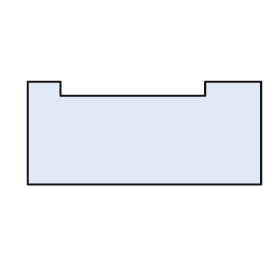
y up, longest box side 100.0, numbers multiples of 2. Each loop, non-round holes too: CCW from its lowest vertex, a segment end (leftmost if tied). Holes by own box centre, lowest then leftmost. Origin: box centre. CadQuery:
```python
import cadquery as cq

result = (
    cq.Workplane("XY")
    .moveTo(-50.0, -22.0)
    .lineTo(50.0, -22.0)
    .lineTo(50.0, 22.0)
    .lineTo(26.0, 22.0)
    .lineTo(26.0, 16.0)
    .lineTo(-36.0, 16.0)
    .lineTo(-36.0, 22.0)
    .lineTo(-50.0, 22.0)
    .close()
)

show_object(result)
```